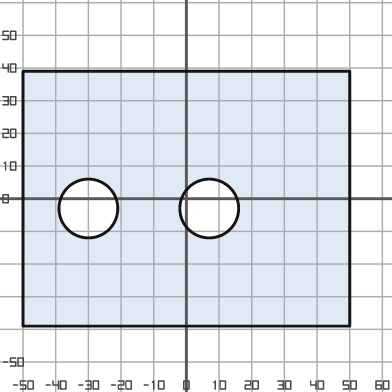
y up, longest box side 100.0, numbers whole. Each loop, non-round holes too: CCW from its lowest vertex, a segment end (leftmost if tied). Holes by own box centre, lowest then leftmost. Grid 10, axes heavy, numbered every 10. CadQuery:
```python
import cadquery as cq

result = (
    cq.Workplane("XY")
    .moveTo(-50.0, -39.0)
    .lineTo(50.0, -39.0)
    .lineTo(50.0, 39.0)
    .lineTo(-50.0, 39.0)
    .close()
    .moveTo(-30.0, -3.0)
    .circle(9.0)
    .moveTo(7.0, -3.0)
    .circle(9.0)
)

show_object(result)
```